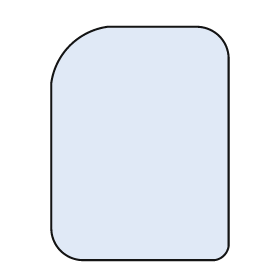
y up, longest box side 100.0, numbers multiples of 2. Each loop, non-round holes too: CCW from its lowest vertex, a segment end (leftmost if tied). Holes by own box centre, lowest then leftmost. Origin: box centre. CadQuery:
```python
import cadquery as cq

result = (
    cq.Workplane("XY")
    .moveTo(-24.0, -50.0)
    .lineTo(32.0, -50.0)
    .threePointArc((36.0, -48.0), (38.0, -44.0))
    .lineTo(38.0, 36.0)
    .threePointArc((34.0, 46.0), (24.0, 50.0))
    .lineTo(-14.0, 50.0)
    .threePointArc((-30.0, 42.0), (-38.0, 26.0))
    .lineTo(-38.0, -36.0)
    .threePointArc((-34.0, -46.0), (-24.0, -50.0))
    .close()
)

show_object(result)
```